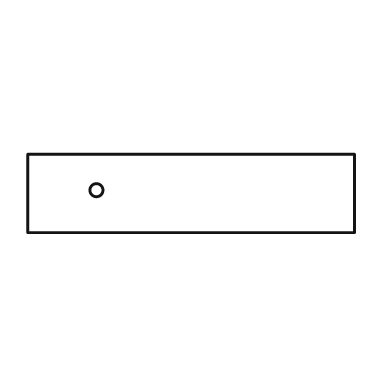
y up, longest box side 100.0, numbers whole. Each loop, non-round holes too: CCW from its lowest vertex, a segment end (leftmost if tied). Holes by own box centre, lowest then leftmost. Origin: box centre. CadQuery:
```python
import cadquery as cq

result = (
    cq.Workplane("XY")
    .moveTo(-50.0, -12.0)
    .lineTo(50.0, -12.0)
    .lineTo(50.0, 12.0)
    .lineTo(-50.0, 12.0)
    .close()
    .moveTo(-29.0, 1.0)
    .circle(2.0)
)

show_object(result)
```